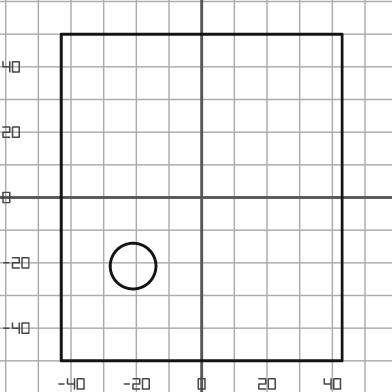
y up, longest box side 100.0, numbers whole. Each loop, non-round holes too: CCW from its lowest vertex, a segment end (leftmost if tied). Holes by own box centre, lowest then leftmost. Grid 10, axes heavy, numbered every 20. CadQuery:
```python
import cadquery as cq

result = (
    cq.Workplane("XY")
    .moveTo(-43.0, -50.0)
    .lineTo(43.0, -50.0)
    .lineTo(43.0, 50.0)
    .lineTo(-43.0, 50.0)
    .close()
    .moveTo(-21.0, -21.0)
    .circle(7.0)
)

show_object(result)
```